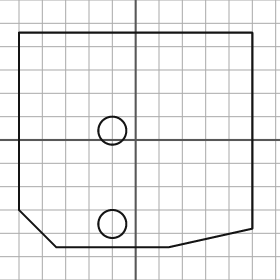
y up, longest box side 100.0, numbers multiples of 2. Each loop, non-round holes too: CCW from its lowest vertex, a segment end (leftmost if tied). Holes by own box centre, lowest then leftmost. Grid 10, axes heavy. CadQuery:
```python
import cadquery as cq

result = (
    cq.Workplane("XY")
    .moveTo(-34.0, -46.0)
    .lineTo(14.0, -46.0)
    .lineTo(50.0, -38.0)
    .lineTo(50.0, 46.0)
    .lineTo(-50.0, 46.0)
    .lineTo(-50.0, -30.0)
    .close()
    .moveTo(-10.0, -36.0)
    .circle(6.0)
    .moveTo(-10.0, 4.0)
    .circle(6.0)
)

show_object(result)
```